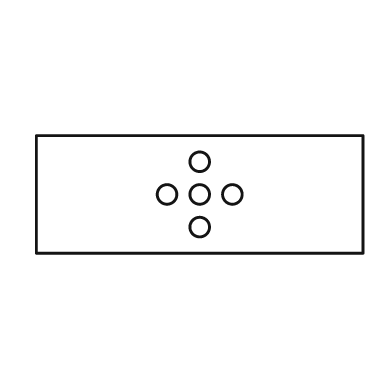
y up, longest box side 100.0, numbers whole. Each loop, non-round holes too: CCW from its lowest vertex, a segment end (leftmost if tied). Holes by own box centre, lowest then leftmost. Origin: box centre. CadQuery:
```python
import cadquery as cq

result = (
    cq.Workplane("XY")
    .moveTo(-50.0, -18.0)
    .lineTo(50.0, -18.0)
    .lineTo(50.0, 18.0)
    .lineTo(-50.0, 18.0)
    .close()
    .moveTo(0.0, -10.0)
    .circle(3.0)
    .moveTo(-10.0, 0.0)
    .circle(3.0)
    .moveTo(0.0, 0.0)
    .circle(3.0)
    .moveTo(10.0, 0.0)
    .circle(3.0)
    .moveTo(0.0, 10.0)
    .circle(3.0)
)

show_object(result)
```